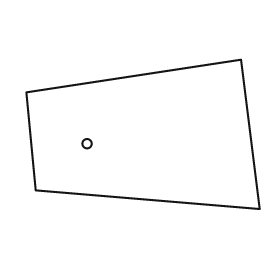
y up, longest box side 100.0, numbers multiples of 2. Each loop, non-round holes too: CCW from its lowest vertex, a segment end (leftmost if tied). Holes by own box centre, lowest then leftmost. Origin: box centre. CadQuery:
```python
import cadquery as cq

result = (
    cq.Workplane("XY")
    .moveTo(50.0, -32.0)
    .lineTo(42.0, 32.0)
    .lineTo(-50.0, 18.0)
    .lineTo(-46.0, -24.0)
    .close()
    .moveTo(-24.0, -4.0)
    .circle(2.0)
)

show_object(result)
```